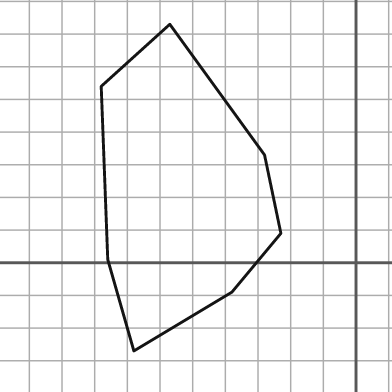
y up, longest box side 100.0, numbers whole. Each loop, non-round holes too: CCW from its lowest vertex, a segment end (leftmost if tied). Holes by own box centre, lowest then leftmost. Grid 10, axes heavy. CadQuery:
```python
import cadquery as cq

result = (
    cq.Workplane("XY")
    .moveTo(-68.0, -27.0)
    .lineTo(-38.0, -9.0)
    .lineTo(-23.0, 9.0)
    .lineTo(-28.0, 33.0)
    .lineTo(-57.0, 73.0)
    .lineTo(-78.0, 54.0)
    .lineTo(-76.0, 1.0)
    .close()
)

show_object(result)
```